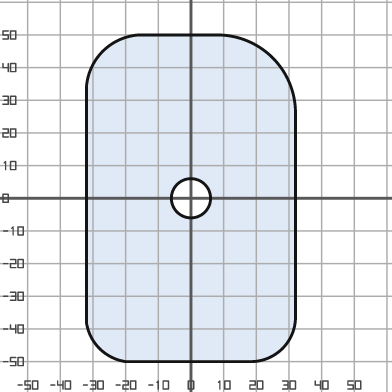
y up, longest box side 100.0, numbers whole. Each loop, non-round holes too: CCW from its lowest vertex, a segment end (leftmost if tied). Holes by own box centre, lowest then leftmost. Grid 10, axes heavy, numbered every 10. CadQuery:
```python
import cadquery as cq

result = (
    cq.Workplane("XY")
    .moveTo(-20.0, -50.0)
    .lineTo(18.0, -50.0)
    .threePointArc((28.0, -46.0), (32.0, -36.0))
    .lineTo(32.0, 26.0)
    .threePointArc((25.0, 43.0), (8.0, 50.0))
    .lineTo(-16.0, 50.0)
    .threePointArc((-27.0, 45.0), (-32.0, 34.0))
    .lineTo(-32.0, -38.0)
    .threePointArc((-28.0, -46.0), (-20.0, -50.0))
    .close()
    .moveTo(0.0, 0.0)
    .circle(6.0)
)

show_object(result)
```